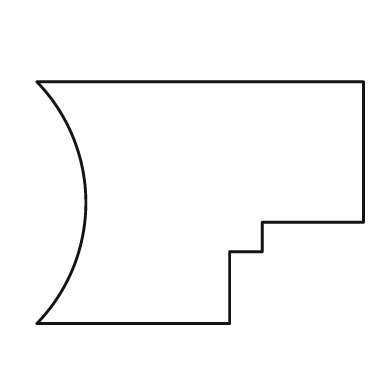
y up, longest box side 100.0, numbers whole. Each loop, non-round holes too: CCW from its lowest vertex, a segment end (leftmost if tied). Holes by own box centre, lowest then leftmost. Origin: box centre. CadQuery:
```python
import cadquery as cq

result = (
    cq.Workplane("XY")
    .moveTo(-50.0, -37.0)
    .lineTo(9.0, -37.0)
    .lineTo(9.0, -15.0)
    .lineTo(19.0, -15.0)
    .lineTo(19.0, -6.0)
    .lineTo(50.0, -6.0)
    .lineTo(50.0, 37.0)
    .lineTo(-50.0, 37.0)
    .threePointArc((-35.0, 0.0), (-50.0, -37.0))
    .close()
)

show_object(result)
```